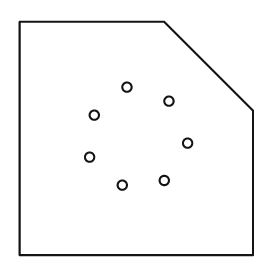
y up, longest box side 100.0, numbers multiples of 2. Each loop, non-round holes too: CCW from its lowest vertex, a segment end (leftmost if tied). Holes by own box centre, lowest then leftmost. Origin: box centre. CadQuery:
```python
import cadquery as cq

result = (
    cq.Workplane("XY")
    .moveTo(-50.0, -50.0)
    .lineTo(50.0, -50.0)
    .lineTo(50.0, 12.0)
    .lineTo(12.0, 50.0)
    .lineTo(-50.0, 50.0)
    .close()
    .moveTo(-6.0, -20.0)
    .circle(2.0)
    .moveTo(12.0, -18.0)
    .circle(2.0)
    .moveTo(-20.0, -8.0)
    .circle(2.0)
    .moveTo(22.0, -2.0)
    .circle(2.0)
    .moveTo(-18.0, 10.0)
    .circle(2.0)
    .moveTo(14.0, 16.0)
    .circle(2.0)
    .moveTo(-4.0, 22.0)
    .circle(2.0)
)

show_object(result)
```